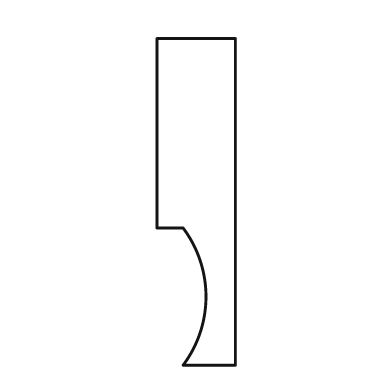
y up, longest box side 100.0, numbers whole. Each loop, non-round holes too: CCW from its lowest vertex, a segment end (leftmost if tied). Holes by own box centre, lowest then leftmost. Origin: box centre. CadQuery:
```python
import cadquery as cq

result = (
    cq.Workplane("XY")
    .moveTo(-4.0, -50.0)
    .lineTo(12.0, -50.0)
    .lineTo(12.0, 50.0)
    .lineTo(-12.0, 50.0)
    .lineTo(-12.0, -8.0)
    .lineTo(-4.0, -8.0)
    .threePointArc((3.0, -29.0), (-4.0, -50.0))
    .close()
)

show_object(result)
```